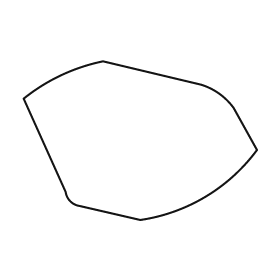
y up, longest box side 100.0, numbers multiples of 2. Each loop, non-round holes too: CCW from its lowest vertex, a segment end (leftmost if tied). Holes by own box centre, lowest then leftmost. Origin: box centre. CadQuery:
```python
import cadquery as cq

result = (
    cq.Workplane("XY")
    .moveTo(0.0, -34.0)
    .threePointArc((28.0, -24.0), (50.0, -4.0))
    .lineTo(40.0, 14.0)
    .threePointArc((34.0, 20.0), (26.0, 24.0))
    .lineTo(-16.0, 34.0)
    .threePointArc((-34.0, 28.0), (-50.0, 18.0))
    .lineTo(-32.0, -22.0)
    .threePointArc((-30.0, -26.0), (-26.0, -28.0))
    .close()
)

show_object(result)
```